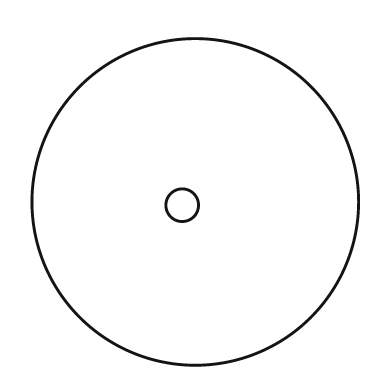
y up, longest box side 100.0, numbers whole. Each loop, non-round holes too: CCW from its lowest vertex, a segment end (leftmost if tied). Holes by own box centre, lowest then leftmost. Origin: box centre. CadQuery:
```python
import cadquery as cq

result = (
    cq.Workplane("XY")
    .moveTo(0.0, 0.0)
    .circle(50.0)
    .moveTo(-4.0, -1.0)
    .circle(5.0)
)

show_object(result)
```